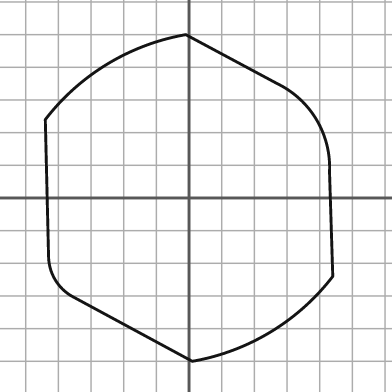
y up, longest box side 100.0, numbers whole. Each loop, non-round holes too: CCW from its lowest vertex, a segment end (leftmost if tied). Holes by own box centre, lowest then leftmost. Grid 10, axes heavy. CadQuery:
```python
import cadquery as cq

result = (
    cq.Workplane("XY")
    .moveTo(1.0, -50.0)
    .threePointArc((25.0, -41.0), (44.0, -24.0))
    .lineTo(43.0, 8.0)
    .threePointArc((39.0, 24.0), (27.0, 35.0))
    .lineTo(-1.0, 50.0)
    .threePointArc((-25.0, 41.0), (-44.0, 24.0))
    .lineTo(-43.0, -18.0)
    .threePointArc((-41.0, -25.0), (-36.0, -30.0))
    .close()
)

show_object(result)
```